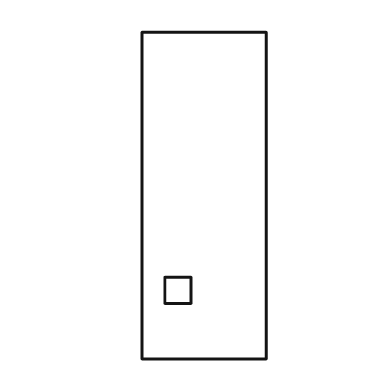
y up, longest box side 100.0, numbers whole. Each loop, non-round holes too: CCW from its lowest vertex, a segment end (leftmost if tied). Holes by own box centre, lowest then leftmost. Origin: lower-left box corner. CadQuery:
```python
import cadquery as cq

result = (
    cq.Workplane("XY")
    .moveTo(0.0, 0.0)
    .lineTo(38.0, 0.0)
    .lineTo(38.0, 100.0)
    .lineTo(0.0, 100.0)
    .close()
    .moveTo(7.0, 17.0)
    .lineTo(15.0, 17.0)
    .lineTo(15.0, 25.0)
    .lineTo(7.0, 25.0)
    .close()
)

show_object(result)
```